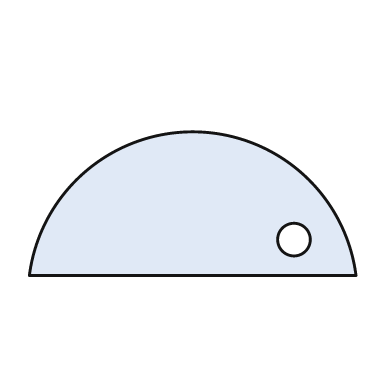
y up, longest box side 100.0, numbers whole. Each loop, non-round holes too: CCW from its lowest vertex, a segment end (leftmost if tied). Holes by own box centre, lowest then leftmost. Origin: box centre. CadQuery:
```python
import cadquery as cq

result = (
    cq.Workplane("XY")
    .moveTo(-50.0, -22.0)
    .lineTo(50.0, -22.0)
    .threePointArc((0.0, 22.0), (-50.0, -22.0))
    .close()
    .moveTo(31.0, -11.0)
    .circle(5.0)
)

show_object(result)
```